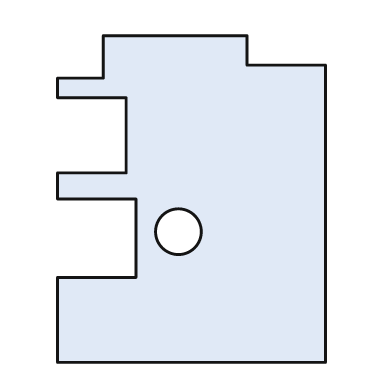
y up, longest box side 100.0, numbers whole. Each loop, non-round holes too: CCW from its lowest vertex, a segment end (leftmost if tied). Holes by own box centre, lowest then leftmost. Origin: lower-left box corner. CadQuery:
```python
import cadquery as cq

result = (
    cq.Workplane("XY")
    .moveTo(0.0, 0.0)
    .lineTo(82.0, 0.0)
    .lineTo(82.0, 91.0)
    .lineTo(58.0, 91.0)
    .lineTo(58.0, 100.0)
    .lineTo(14.0, 100.0)
    .lineTo(14.0, 87.0)
    .lineTo(0.0, 87.0)
    .lineTo(0.0, 81.0)
    .lineTo(21.0, 81.0)
    .lineTo(21.0, 58.0)
    .lineTo(0.0, 58.0)
    .lineTo(0.0, 50.0)
    .lineTo(24.0, 50.0)
    .lineTo(24.0, 26.0)
    .lineTo(0.0, 26.0)
    .close()
    .moveTo(37.0, 40.0)
    .circle(7.0)
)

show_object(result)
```